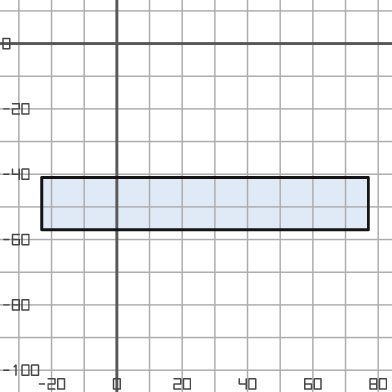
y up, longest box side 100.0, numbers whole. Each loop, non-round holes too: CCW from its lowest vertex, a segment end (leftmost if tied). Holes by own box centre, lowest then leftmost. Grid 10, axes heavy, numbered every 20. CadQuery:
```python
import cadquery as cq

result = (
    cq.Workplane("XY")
    .moveTo(-23.0, -57.0)
    .lineTo(77.0, -57.0)
    .lineTo(77.0, -41.0)
    .lineTo(-23.0, -41.0)
    .close()
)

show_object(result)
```